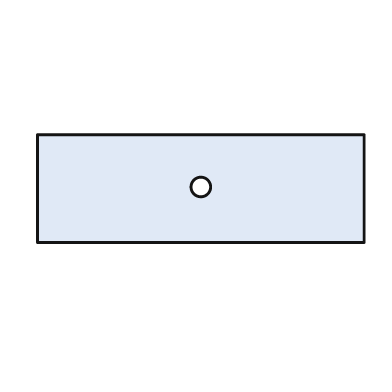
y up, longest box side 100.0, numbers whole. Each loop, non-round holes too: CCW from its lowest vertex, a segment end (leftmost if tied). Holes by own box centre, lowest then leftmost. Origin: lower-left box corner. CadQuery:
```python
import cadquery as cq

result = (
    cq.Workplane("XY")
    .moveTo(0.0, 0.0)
    .lineTo(100.0, 0.0)
    .lineTo(100.0, 33.0)
    .lineTo(0.0, 33.0)
    .close()
    .moveTo(50.0, 17.0)
    .circle(3.0)
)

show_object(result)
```